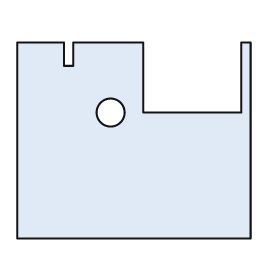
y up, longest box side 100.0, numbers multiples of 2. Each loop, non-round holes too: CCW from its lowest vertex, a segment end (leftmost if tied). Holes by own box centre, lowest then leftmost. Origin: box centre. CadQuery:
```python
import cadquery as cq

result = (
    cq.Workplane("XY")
    .moveTo(-50.0, -42.0)
    .lineTo(50.0, -42.0)
    .lineTo(50.0, 42.0)
    .lineTo(46.0, 42.0)
    .lineTo(46.0, 12.0)
    .lineTo(4.0, 12.0)
    .lineTo(4.0, 42.0)
    .lineTo(-26.0, 42.0)
    .lineTo(-26.0, 32.0)
    .lineTo(-30.0, 32.0)
    .lineTo(-30.0, 42.0)
    .lineTo(-50.0, 42.0)
    .close()
    .moveTo(-10.0, 12.0)
    .circle(6.0)
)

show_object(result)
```